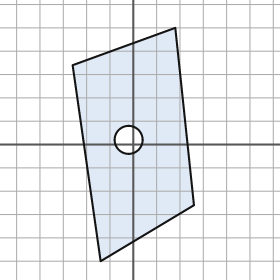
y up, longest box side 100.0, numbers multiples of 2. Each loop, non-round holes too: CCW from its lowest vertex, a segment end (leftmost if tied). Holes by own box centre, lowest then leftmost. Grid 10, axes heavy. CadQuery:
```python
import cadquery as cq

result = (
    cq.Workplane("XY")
    .moveTo(-14.0, -50.0)
    .lineTo(26.0, -26.0)
    .lineTo(18.0, 50.0)
    .lineTo(-26.0, 34.0)
    .close()
    .moveTo(-2.0, 2.0)
    .circle(6.0)
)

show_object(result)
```